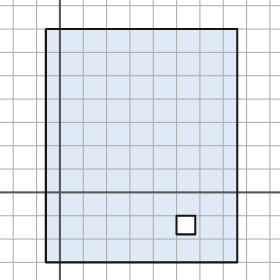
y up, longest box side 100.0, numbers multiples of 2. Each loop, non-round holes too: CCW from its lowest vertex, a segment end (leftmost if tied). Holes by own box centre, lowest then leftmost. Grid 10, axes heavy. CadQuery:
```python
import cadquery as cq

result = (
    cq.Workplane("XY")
    .moveTo(-6.0, -30.0)
    .lineTo(76.0, -30.0)
    .lineTo(76.0, 70.0)
    .lineTo(-6.0, 70.0)
    .close()
    .moveTo(50.0, -18.0)
    .lineTo(58.0, -18.0)
    .lineTo(58.0, -10.0)
    .lineTo(50.0, -10.0)
    .close()
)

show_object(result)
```